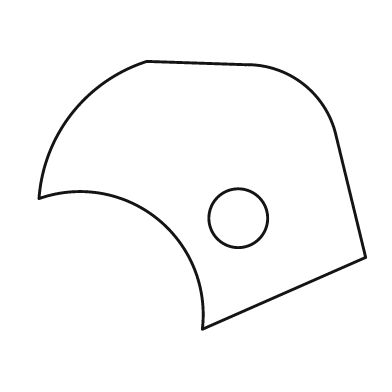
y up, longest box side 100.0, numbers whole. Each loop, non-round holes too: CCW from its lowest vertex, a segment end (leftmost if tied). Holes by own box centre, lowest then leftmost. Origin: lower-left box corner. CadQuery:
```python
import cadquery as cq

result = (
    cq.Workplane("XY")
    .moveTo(50.0, 0.0)
    .lineTo(100.0, 22.0)
    .lineTo(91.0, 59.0)
    .threePointArc((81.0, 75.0), (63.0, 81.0))
    .lineTo(33.0, 82.0)
    .threePointArc((10.0, 66.0), (0.0, 40.0))
    .threePointArc((36.0, 34.0), (50.0, 0.0))
    .close()
    .moveTo(61.0, 34.0)
    .circle(9.0)
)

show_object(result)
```